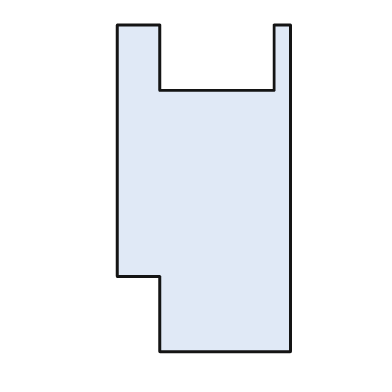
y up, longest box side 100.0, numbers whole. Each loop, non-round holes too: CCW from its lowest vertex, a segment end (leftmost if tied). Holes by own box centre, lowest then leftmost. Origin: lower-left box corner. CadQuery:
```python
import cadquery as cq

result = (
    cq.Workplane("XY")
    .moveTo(13.0, 0.0)
    .lineTo(53.0, 0.0)
    .lineTo(53.0, 100.0)
    .lineTo(48.0, 100.0)
    .lineTo(48.0, 80.0)
    .lineTo(13.0, 80.0)
    .lineTo(13.0, 100.0)
    .lineTo(0.0, 100.0)
    .lineTo(0.0, 23.0)
    .lineTo(13.0, 23.0)
    .close()
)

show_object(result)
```